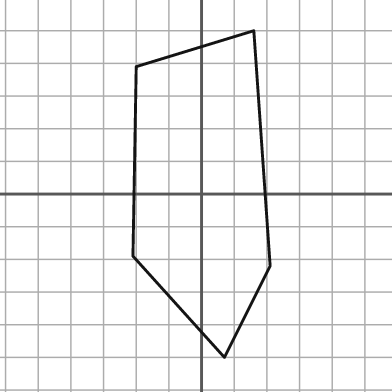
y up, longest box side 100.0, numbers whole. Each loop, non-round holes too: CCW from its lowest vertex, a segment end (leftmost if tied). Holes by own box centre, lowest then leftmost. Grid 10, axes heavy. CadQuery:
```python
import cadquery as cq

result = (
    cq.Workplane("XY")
    .moveTo(7.0, -50.0)
    .lineTo(21.0, -22.0)
    .lineTo(16.0, 50.0)
    .lineTo(-20.0, 39.0)
    .lineTo(-21.0, -19.0)
    .close()
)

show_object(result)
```